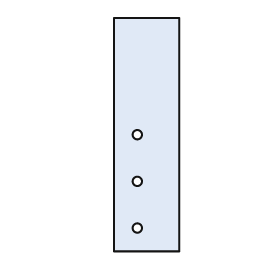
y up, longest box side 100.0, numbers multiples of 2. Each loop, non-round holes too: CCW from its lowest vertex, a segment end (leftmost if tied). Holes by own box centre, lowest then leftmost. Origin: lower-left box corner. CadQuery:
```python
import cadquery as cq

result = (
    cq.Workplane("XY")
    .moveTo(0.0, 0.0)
    .lineTo(28.0, 0.0)
    .lineTo(28.0, 100.0)
    .lineTo(0.0, 100.0)
    .close()
    .moveTo(10.0, 10.0)
    .circle(2.0)
    .moveTo(10.0, 30.0)
    .circle(2.0)
    .moveTo(10.0, 50.0)
    .circle(2.0)
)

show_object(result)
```